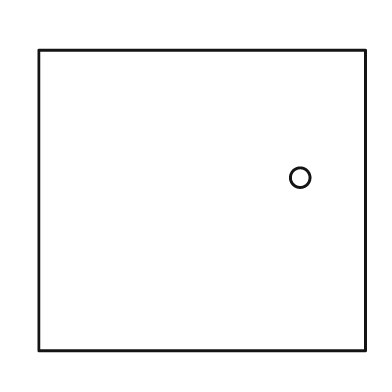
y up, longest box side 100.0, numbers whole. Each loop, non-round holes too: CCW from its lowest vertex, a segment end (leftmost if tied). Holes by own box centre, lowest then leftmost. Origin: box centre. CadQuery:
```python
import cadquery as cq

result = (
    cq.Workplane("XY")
    .moveTo(-50.0, -46.0)
    .lineTo(50.0, -46.0)
    .lineTo(50.0, 46.0)
    .lineTo(-50.0, 46.0)
    .close()
    .moveTo(30.0, 7.0)
    .circle(3.0)
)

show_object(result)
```